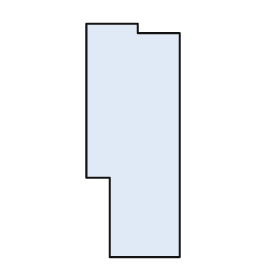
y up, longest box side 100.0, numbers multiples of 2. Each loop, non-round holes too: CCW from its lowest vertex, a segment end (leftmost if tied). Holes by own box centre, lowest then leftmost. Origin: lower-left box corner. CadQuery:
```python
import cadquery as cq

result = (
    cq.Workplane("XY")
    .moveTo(10.0, 0.0)
    .lineTo(40.0, 0.0)
    .lineTo(40.0, 96.0)
    .lineTo(22.0, 96.0)
    .lineTo(22.0, 100.0)
    .lineTo(0.0, 100.0)
    .lineTo(0.0, 34.0)
    .lineTo(10.0, 34.0)
    .close()
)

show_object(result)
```